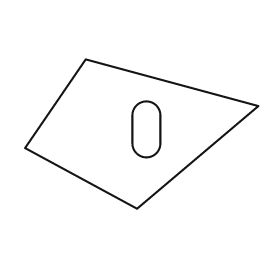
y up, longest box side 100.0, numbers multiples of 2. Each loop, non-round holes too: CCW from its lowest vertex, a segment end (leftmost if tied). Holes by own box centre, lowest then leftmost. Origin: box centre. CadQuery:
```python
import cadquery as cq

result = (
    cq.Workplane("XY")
    .moveTo(-2.0, -32.0)
    .lineTo(50.0, 12.0)
    .lineTo(-24.0, 32.0)
    .lineTo(-50.0, -6.0)
    .close()
    .moveTo(-4.0, -4.0)
    .threePointArc((2.0, -10.0), (8.0, -4.0))
    .lineTo(8.0, 8.0)
    .threePointArc((2.0, 14.0), (-4.0, 8.0))
    .close()
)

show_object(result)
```